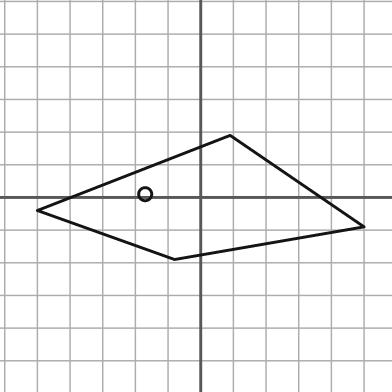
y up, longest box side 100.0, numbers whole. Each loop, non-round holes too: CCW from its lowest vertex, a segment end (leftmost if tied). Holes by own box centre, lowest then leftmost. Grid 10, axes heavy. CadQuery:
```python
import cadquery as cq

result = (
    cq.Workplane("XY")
    .moveTo(-8.0, -19.0)
    .lineTo(50.0, -9.0)
    .lineTo(9.0, 19.0)
    .lineTo(-50.0, -4.0)
    .close()
    .moveTo(-17.0, 1.0)
    .circle(2.0)
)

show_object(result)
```